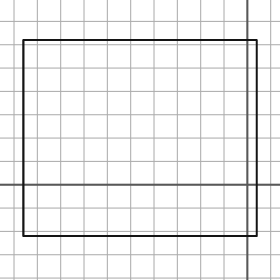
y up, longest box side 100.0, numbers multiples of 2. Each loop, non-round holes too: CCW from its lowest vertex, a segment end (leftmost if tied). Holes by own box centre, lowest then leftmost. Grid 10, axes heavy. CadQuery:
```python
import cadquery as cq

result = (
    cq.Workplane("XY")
    .moveTo(-96.0, -22.0)
    .lineTo(4.0, -22.0)
    .lineTo(4.0, 62.0)
    .lineTo(-96.0, 62.0)
    .close()
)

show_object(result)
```